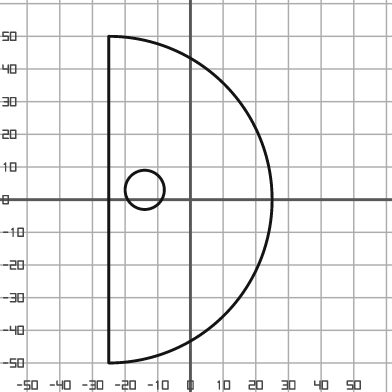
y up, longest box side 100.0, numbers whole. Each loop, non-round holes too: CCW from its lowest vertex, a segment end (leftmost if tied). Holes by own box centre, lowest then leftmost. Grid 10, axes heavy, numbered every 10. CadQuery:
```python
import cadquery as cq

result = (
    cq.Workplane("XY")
    .moveTo(-25.0, -50.0)
    .threePointArc((25.0, 0.0), (-25.0, 50.0))
    .close()
    .moveTo(-14.0, 3.0)
    .circle(6.0)
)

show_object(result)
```